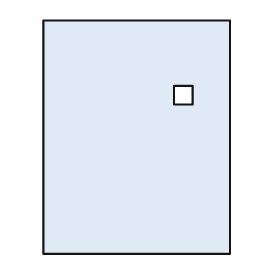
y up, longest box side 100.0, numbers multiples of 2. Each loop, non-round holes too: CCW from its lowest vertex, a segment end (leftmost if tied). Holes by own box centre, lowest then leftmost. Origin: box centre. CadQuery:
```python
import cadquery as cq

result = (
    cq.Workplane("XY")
    .moveTo(-40.0, -50.0)
    .lineTo(40.0, -50.0)
    .lineTo(40.0, 50.0)
    .lineTo(-40.0, 50.0)
    .close()
    .moveTo(16.0, 14.0)
    .lineTo(24.0, 14.0)
    .lineTo(24.0, 22.0)
    .lineTo(16.0, 22.0)
    .close()
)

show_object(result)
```